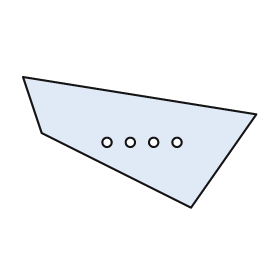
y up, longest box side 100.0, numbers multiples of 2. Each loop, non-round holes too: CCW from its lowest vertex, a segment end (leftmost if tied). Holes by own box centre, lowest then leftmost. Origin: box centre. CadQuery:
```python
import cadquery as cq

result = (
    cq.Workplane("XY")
    .moveTo(22.0, -28.0)
    .lineTo(50.0, 12.0)
    .lineTo(-50.0, 28.0)
    .lineTo(-42.0, 4.0)
    .close()
    .moveTo(-14.0, 0.0)
    .circle(2.0)
    .moveTo(-4.0, 0.0)
    .circle(2.0)
    .moveTo(6.0, 0.0)
    .circle(2.0)
    .moveTo(16.0, 0.0)
    .circle(2.0)
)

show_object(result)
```